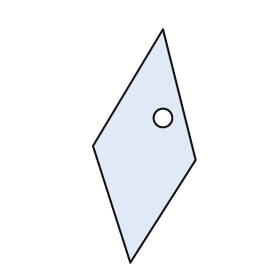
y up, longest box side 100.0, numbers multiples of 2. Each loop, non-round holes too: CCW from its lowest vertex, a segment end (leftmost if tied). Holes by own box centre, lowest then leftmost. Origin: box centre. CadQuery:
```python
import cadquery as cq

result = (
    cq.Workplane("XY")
    .moveTo(-6.0, -50.0)
    .lineTo(22.0, -6.0)
    .lineTo(8.0, 50.0)
    .lineTo(-22.0, 0.0)
    .close()
    .moveTo(8.0, 12.0)
    .circle(4.0)
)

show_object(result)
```